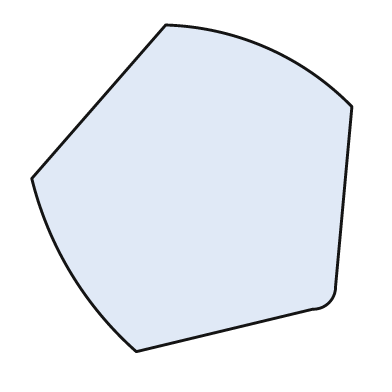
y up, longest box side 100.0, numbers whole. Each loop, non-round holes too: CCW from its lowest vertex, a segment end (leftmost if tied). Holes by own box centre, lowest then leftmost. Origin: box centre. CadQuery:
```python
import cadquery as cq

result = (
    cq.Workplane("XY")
    .moveTo(-17.0, -50.0)
    .lineTo(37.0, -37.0)
    .threePointArc((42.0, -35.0), (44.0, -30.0))
    .lineTo(49.0, 25.0)
    .threePointArc((23.0, 43.0), (-8.0, 50.0))
    .lineTo(-49.0, 3.0)
    .threePointArc((-37.0, -26.0), (-17.0, -50.0))
    .close()
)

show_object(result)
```